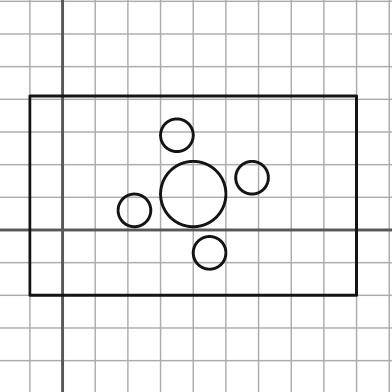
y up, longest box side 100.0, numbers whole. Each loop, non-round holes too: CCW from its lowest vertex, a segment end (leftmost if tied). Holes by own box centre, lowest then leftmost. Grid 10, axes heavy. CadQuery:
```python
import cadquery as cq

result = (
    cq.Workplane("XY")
    .moveTo(-10.0, -20.0)
    .lineTo(90.0, -20.0)
    .lineTo(90.0, 41.0)
    .lineTo(-10.0, 41.0)
    .close()
    .moveTo(45.0, -7.0)
    .circle(5.0)
    .moveTo(22.0, 6.0)
    .circle(5.0)
    .moveTo(40.0, 11.0)
    .circle(10.0)
    .moveTo(58.0, 16.0)
    .circle(5.0)
    .moveTo(35.0, 29.0)
    .circle(5.0)
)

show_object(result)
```